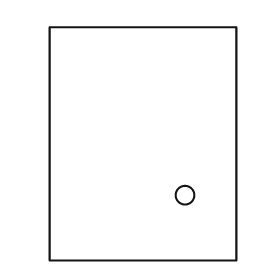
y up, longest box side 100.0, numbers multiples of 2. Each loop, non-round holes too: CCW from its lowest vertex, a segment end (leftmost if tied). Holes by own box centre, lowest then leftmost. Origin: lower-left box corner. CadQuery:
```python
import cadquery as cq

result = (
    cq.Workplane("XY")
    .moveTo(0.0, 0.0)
    .lineTo(80.0, 0.0)
    .lineTo(80.0, 100.0)
    .lineTo(0.0, 100.0)
    .close()
    .moveTo(58.0, 28.0)
    .circle(4.0)
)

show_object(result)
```